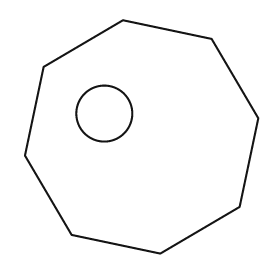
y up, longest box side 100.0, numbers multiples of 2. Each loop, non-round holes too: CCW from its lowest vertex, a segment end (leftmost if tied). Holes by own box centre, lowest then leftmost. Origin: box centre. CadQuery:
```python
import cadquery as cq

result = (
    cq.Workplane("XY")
    .moveTo(8.0, -50.0)
    .lineTo(42.0, -30.0)
    .lineTo(50.0, 8.0)
    .lineTo(30.0, 42.0)
    .lineTo(-8.0, 50.0)
    .lineTo(-42.0, 30.0)
    .lineTo(-50.0, -8.0)
    .lineTo(-30.0, -42.0)
    .close()
    .moveTo(-16.0, 10.0)
    .circle(12.0)
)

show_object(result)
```